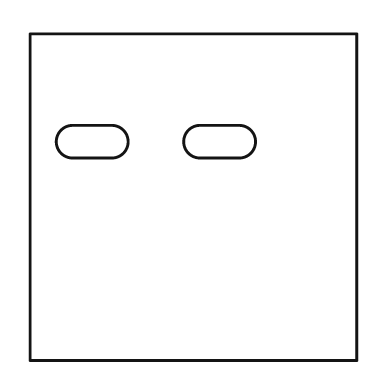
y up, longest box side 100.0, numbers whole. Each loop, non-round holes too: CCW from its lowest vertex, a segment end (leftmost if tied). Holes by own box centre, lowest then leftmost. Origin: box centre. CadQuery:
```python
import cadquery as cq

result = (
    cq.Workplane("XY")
    .moveTo(-50.0, -50.0)
    .lineTo(50.0, -50.0)
    .lineTo(50.0, 50.0)
    .lineTo(-50.0, 50.0)
    .close()
    .moveTo(-37.0, 12.0)
    .lineTo(-25.0, 12.0)
    .threePointArc((-20.0, 17.0), (-25.0, 22.0))
    .lineTo(-37.0, 22.0)
    .threePointArc((-42.0, 17.0), (-37.0, 12.0))
    .close()
    .moveTo(2.0, 12.0)
    .lineTo(14.0, 12.0)
    .threePointArc((19.0, 17.0), (14.0, 22.0))
    .lineTo(2.0, 22.0)
    .threePointArc((-3.0, 17.0), (2.0, 12.0))
    .close()
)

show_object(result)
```